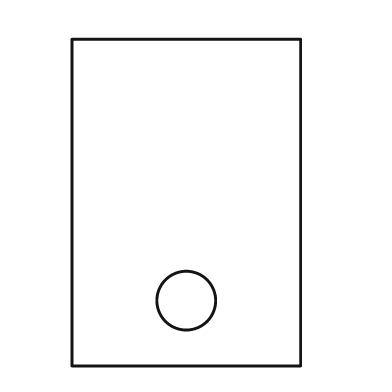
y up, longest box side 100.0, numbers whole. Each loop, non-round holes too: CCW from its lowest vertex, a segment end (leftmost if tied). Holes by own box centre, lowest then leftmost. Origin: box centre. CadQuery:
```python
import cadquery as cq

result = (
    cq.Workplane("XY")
    .moveTo(-35.0, -50.0)
    .lineTo(35.0, -50.0)
    .lineTo(35.0, 50.0)
    .lineTo(-35.0, 50.0)
    .close()
    .moveTo(0.0, -30.0)
    .circle(9.0)
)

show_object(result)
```